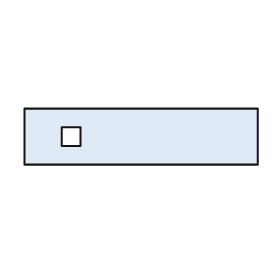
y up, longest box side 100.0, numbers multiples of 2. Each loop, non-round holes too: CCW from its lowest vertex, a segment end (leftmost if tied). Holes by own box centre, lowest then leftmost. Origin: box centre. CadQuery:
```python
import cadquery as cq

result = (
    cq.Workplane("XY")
    .moveTo(-50.0, -12.0)
    .lineTo(50.0, -12.0)
    .lineTo(50.0, 12.0)
    .lineTo(-50.0, 12.0)
    .close()
    .moveTo(-34.0, -4.0)
    .lineTo(-26.0, -4.0)
    .lineTo(-26.0, 4.0)
    .lineTo(-34.0, 4.0)
    .close()
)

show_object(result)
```